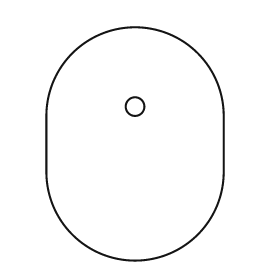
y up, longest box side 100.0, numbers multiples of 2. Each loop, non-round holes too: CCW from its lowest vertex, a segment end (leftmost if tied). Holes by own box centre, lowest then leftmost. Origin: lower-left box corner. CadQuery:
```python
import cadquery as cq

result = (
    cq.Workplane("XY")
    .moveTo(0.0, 38.0)
    .threePointArc((38.0, 0.0), (76.0, 38.0))
    .lineTo(76.0, 62.0)
    .threePointArc((38.0, 100.0), (0.0, 62.0))
    .close()
    .moveTo(38.0, 66.0)
    .circle(4.0)
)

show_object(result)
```